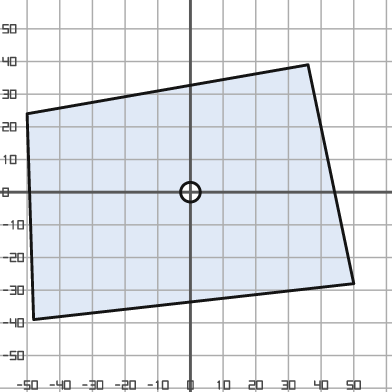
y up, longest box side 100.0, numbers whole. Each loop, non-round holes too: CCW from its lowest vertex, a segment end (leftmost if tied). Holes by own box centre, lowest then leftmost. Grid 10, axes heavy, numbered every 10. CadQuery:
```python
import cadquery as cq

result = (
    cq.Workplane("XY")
    .moveTo(-48.0, -39.0)
    .lineTo(50.0, -28.0)
    .lineTo(36.0, 39.0)
    .lineTo(-50.0, 24.0)
    .close()
    .moveTo(0.0, 0.0)
    .circle(3.0)
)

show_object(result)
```